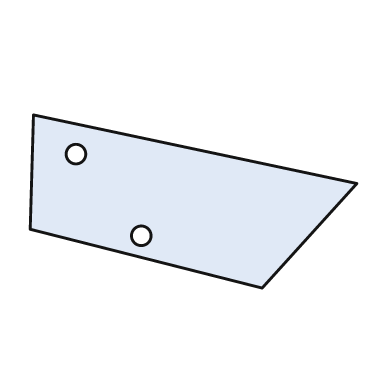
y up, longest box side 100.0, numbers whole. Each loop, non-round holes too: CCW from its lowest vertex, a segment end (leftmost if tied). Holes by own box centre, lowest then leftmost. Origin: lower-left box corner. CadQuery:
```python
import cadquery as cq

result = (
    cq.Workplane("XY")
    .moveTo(71.0, 0.0)
    .lineTo(100.0, 32.0)
    .lineTo(1.0, 53.0)
    .lineTo(0.0, 18.0)
    .close()
    .moveTo(34.0, 16.0)
    .circle(3.0)
    .moveTo(14.0, 41.0)
    .circle(3.0)
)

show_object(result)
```